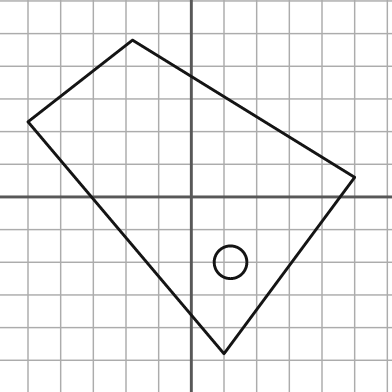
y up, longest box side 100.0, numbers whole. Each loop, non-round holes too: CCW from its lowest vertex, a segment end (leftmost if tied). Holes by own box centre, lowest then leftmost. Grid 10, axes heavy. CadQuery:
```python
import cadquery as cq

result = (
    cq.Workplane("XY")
    .moveTo(10.0, -48.0)
    .lineTo(50.0, 6.0)
    .lineTo(-18.0, 48.0)
    .lineTo(-50.0, 23.0)
    .close()
    .moveTo(12.0, -20.0)
    .circle(5.0)
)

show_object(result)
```